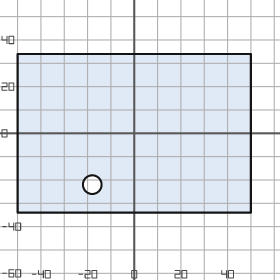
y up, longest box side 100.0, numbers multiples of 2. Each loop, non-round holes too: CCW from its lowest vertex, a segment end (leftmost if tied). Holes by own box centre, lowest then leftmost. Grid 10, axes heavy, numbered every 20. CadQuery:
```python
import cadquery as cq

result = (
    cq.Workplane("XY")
    .moveTo(-50.0, -34.0)
    .lineTo(50.0, -34.0)
    .lineTo(50.0, 34.0)
    .lineTo(-50.0, 34.0)
    .close()
    .moveTo(-18.0, -22.0)
    .circle(4.0)
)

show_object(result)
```